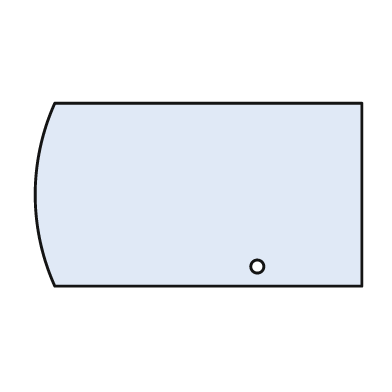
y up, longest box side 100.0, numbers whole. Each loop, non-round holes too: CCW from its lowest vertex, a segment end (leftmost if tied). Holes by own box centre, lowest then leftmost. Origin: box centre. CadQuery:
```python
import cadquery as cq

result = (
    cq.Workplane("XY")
    .moveTo(-44.0, -28.0)
    .lineTo(50.0, -28.0)
    .lineTo(50.0, 28.0)
    .lineTo(-44.0, 28.0)
    .threePointArc((-50.0, 0.0), (-44.0, -28.0))
    .close()
    .moveTo(18.0, -22.0)
    .circle(2.0)
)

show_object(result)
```